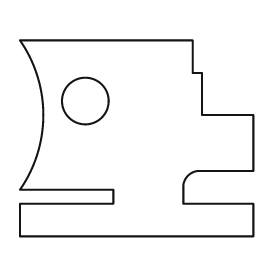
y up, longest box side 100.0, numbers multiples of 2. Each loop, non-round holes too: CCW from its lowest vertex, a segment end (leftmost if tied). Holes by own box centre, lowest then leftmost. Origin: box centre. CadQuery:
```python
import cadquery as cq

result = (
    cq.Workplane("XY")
    .moveTo(-50.0, -42.0)
    .lineTo(50.0, -42.0)
    .lineTo(50.0, -28.0)
    .lineTo(20.0, -28.0)
    .lineTo(20.0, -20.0)
    .threePointArc((22.0, -16.0), (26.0, -14.0))
    .lineTo(50.0, -14.0)
    .lineTo(50.0, 10.0)
    .lineTo(28.0, 10.0)
    .lineTo(28.0, 28.0)
    .lineTo(24.0, 28.0)
    .lineTo(24.0, 42.0)
    .lineTo(-50.0, 42.0)
    .threePointArc((-40.0, 10.0), (-50.0, -22.0))
    .lineTo(-10.0, -22.0)
    .lineTo(-10.0, -28.0)
    .lineTo(-50.0, -28.0)
    .close()
    .moveTo(-22.0, 16.0)
    .circle(10.0)
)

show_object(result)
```